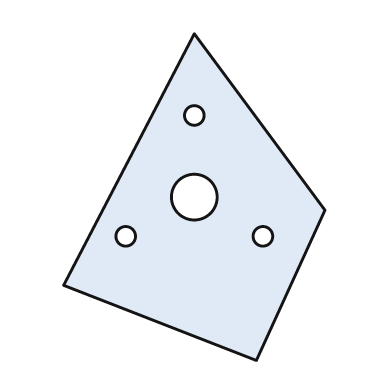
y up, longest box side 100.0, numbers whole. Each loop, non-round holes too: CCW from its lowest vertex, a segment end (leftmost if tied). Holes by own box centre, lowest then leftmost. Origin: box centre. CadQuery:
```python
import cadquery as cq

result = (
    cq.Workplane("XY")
    .moveTo(19.0, -50.0)
    .lineTo(40.0, -4.0)
    .lineTo(0.0, 50.0)
    .lineTo(-40.0, -27.0)
    .close()
    .moveTo(-21.0, -12.0)
    .circle(3.0)
    .moveTo(21.0, -12.0)
    .circle(3.0)
    .moveTo(0.0, 0.0)
    .circle(7.0)
    .moveTo(0.0, 25.0)
    .circle(3.0)
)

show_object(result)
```